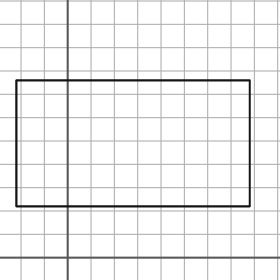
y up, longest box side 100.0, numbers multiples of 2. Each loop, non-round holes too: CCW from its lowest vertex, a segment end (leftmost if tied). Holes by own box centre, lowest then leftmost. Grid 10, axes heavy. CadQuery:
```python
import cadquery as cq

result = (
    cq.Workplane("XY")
    .moveTo(-22.0, 22.0)
    .lineTo(78.0, 22.0)
    .lineTo(78.0, 76.0)
    .lineTo(-22.0, 76.0)
    .close()
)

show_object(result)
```